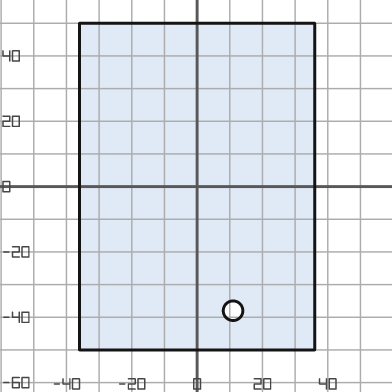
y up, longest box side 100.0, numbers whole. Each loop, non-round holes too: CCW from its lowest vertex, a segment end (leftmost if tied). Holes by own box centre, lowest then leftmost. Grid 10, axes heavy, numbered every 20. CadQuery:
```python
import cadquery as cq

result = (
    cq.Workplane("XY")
    .moveTo(-36.0, -50.0)
    .lineTo(36.0, -50.0)
    .lineTo(36.0, 50.0)
    .lineTo(-36.0, 50.0)
    .close()
    .moveTo(11.0, -38.0)
    .circle(3.0)
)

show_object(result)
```